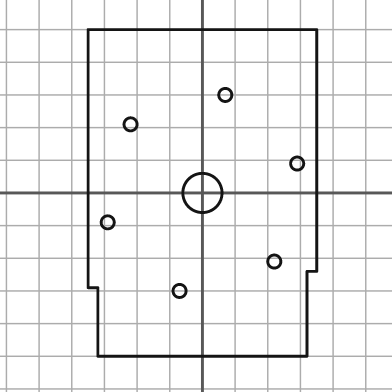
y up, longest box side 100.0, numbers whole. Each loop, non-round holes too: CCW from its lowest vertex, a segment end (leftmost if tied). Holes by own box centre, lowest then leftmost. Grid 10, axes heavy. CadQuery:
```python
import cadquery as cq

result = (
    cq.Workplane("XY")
    .moveTo(-32.0, -50.0)
    .lineTo(32.0, -50.0)
    .lineTo(32.0, -24.0)
    .lineTo(35.0, -24.0)
    .lineTo(35.0, 50.0)
    .lineTo(-35.0, 50.0)
    .lineTo(-35.0, -29.0)
    .lineTo(-32.0, -29.0)
    .close()
    .moveTo(-7.0, -30.0)
    .circle(2.0)
    .moveTo(22.0, -21.0)
    .circle(2.0)
    .moveTo(-29.0, -9.0)
    .circle(2.0)
    .moveTo(0.0, 0.0)
    .circle(6.0)
    .moveTo(29.0, 9.0)
    .circle(2.0)
    .moveTo(-22.0, 21.0)
    .circle(2.0)
    .moveTo(7.0, 30.0)
    .circle(2.0)
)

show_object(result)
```